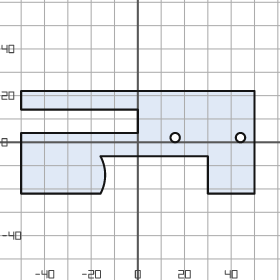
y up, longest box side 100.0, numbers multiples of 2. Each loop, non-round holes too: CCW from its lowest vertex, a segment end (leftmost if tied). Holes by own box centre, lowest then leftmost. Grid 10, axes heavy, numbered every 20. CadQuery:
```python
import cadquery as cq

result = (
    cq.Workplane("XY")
    .moveTo(-50.0, -22.0)
    .lineTo(-16.0, -22.0)
    .threePointArc((-14.0, -14.0), (-16.0, -6.0))
    .lineTo(30.0, -6.0)
    .lineTo(30.0, -22.0)
    .lineTo(50.0, -22.0)
    .lineTo(50.0, 22.0)
    .lineTo(-50.0, 22.0)
    .lineTo(-50.0, 14.0)
    .lineTo(0.0, 14.0)
    .lineTo(0.0, 4.0)
    .lineTo(-50.0, 4.0)
    .close()
    .moveTo(16.0, 2.0)
    .circle(2.0)
    .moveTo(44.0, 2.0)
    .circle(2.0)
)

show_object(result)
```